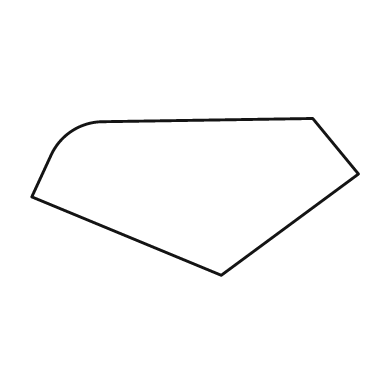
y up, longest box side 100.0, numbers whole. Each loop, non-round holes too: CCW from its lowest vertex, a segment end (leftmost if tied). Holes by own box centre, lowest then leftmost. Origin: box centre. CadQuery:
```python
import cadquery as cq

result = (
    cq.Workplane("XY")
    .moveTo(8.0, -24.0)
    .lineTo(50.0, 7.0)
    .lineTo(36.0, 24.0)
    .lineTo(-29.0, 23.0)
    .threePointArc((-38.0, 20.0), (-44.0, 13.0))
    .lineTo(-50.0, 0.0)
    .close()
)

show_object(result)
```